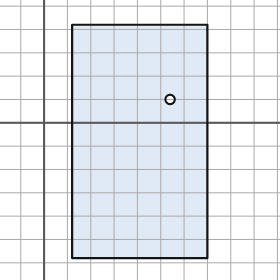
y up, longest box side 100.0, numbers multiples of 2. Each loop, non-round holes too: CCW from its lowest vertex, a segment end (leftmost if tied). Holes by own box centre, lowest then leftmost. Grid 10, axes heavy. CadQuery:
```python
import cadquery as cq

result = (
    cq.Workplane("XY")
    .moveTo(12.0, -58.0)
    .lineTo(70.0, -58.0)
    .lineTo(70.0, 42.0)
    .lineTo(12.0, 42.0)
    .close()
    .moveTo(54.0, 10.0)
    .circle(2.0)
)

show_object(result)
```